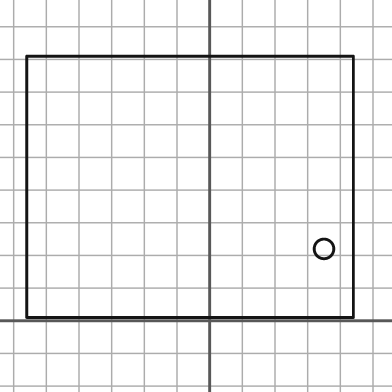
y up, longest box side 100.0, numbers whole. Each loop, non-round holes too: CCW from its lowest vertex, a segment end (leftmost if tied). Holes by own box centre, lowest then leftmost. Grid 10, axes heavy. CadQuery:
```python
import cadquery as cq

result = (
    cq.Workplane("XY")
    .moveTo(-56.0, 1.0)
    .lineTo(44.0, 1.0)
    .lineTo(44.0, 81.0)
    .lineTo(-56.0, 81.0)
    .close()
    .moveTo(35.0, 22.0)
    .circle(3.0)
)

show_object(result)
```